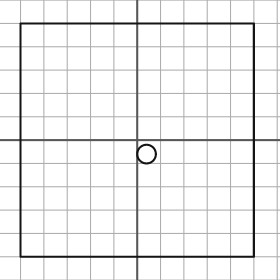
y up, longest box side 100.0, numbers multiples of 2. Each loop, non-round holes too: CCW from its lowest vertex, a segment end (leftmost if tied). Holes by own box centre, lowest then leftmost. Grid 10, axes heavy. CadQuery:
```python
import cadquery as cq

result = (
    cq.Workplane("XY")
    .moveTo(-50.0, -50.0)
    .lineTo(50.0, -50.0)
    .lineTo(50.0, 50.0)
    .lineTo(-50.0, 50.0)
    .close()
    .moveTo(4.0, -6.0)
    .circle(4.0)
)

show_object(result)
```